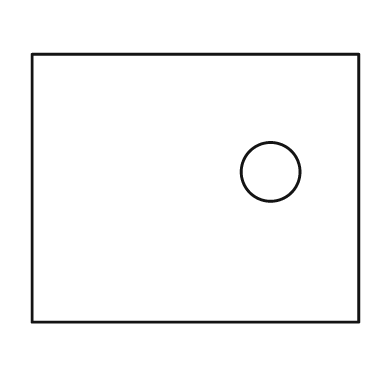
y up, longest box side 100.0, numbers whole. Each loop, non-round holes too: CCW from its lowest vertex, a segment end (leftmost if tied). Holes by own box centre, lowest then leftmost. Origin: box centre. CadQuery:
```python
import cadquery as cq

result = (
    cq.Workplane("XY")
    .moveTo(-50.0, -41.0)
    .lineTo(50.0, -41.0)
    .lineTo(50.0, 41.0)
    .lineTo(-50.0, 41.0)
    .close()
    .moveTo(23.0, 5.0)
    .circle(9.0)
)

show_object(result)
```